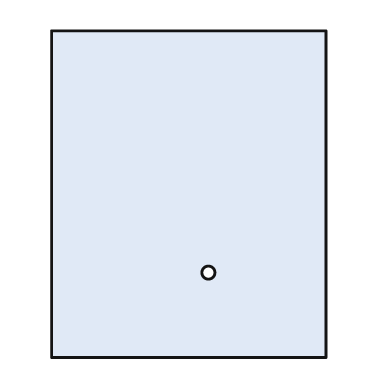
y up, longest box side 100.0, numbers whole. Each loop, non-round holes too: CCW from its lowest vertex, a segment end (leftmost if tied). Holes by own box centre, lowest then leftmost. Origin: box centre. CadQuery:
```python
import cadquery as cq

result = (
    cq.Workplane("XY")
    .moveTo(-42.0, -50.0)
    .lineTo(42.0, -50.0)
    .lineTo(42.0, 50.0)
    .lineTo(-42.0, 50.0)
    .close()
    .moveTo(6.0, -24.0)
    .circle(2.0)
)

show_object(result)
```